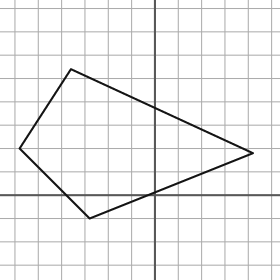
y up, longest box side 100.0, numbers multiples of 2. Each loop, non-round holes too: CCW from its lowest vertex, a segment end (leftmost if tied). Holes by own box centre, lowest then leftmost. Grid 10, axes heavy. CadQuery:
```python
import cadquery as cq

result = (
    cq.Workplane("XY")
    .moveTo(-28.0, -10.0)
    .lineTo(42.0, 18.0)
    .lineTo(-36.0, 54.0)
    .lineTo(-58.0, 20.0)
    .close()
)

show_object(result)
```